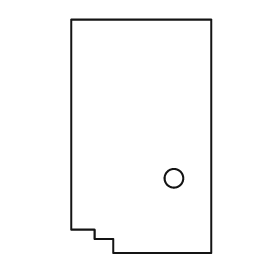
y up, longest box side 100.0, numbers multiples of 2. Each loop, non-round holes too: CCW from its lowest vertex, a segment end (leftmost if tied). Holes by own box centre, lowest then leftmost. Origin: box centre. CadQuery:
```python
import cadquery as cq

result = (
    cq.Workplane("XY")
    .moveTo(-12.0, -50.0)
    .lineTo(30.0, -50.0)
    .lineTo(30.0, 50.0)
    .lineTo(-30.0, 50.0)
    .lineTo(-30.0, -40.0)
    .lineTo(-20.0, -40.0)
    .lineTo(-20.0, -44.0)
    .lineTo(-12.0, -44.0)
    .close()
    .moveTo(14.0, -18.0)
    .circle(4.0)
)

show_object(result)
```